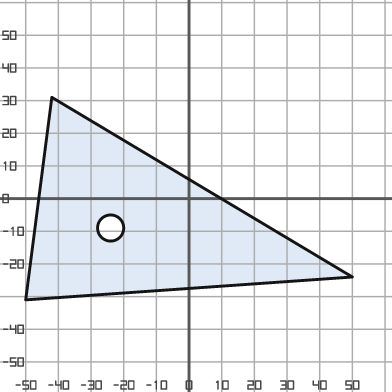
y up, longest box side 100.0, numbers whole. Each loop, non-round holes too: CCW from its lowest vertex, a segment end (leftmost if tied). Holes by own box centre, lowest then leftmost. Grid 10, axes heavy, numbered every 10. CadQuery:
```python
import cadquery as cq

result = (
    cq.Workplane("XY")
    .moveTo(-50.0, -31.0)
    .lineTo(50.0, -24.0)
    .lineTo(-42.0, 31.0)
    .close()
    .moveTo(-24.0, -9.0)
    .circle(4.0)
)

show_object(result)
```